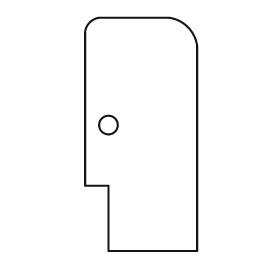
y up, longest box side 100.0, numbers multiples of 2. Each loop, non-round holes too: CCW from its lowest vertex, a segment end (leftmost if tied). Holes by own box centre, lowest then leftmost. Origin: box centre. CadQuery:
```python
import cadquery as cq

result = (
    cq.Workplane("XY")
    .moveTo(-14.0, -50.0)
    .lineTo(24.0, -50.0)
    .lineTo(24.0, 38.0)
    .threePointArc((20.0, 46.0), (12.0, 50.0))
    .lineTo(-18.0, 50.0)
    .threePointArc((-22.0, 48.0), (-24.0, 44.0))
    .lineTo(-24.0, -22.0)
    .lineTo(-14.0, -22.0)
    .close()
    .moveTo(-14.0, 4.0)
    .circle(4.0)
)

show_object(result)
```